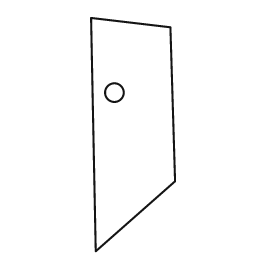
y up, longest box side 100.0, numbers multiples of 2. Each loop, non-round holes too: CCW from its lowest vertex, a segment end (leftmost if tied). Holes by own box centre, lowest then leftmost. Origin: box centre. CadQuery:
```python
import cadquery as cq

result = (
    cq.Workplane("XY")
    .moveTo(-16.0, -50.0)
    .lineTo(18.0, -20.0)
    .lineTo(16.0, 46.0)
    .lineTo(-18.0, 50.0)
    .close()
    .moveTo(-8.0, 18.0)
    .circle(4.0)
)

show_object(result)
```